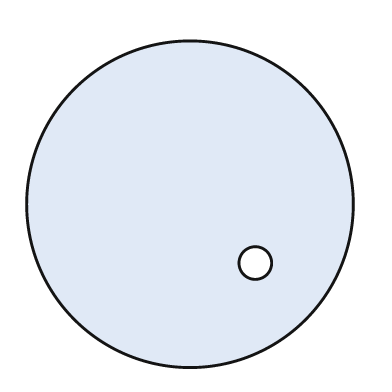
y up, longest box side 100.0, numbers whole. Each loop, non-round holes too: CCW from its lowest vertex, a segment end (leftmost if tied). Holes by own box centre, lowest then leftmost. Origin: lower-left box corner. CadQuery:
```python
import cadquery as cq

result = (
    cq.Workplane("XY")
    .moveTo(50.0, 50.0)
    .circle(50.0)
    .moveTo(70.0, 32.0)
    .circle(5.0)
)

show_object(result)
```